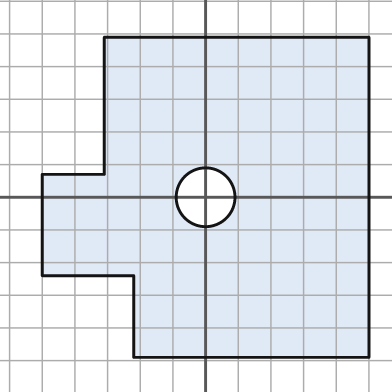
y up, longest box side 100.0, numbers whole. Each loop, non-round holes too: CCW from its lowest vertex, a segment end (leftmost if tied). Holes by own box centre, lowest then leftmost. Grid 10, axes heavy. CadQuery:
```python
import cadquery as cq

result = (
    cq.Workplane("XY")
    .moveTo(-22.0, -49.0)
    .lineTo(50.0, -49.0)
    .lineTo(50.0, 49.0)
    .lineTo(-31.0, 49.0)
    .lineTo(-31.0, 7.0)
    .lineTo(-50.0, 7.0)
    .lineTo(-50.0, -24.0)
    .lineTo(-22.0, -24.0)
    .close()
    .moveTo(0.0, 0.0)
    .circle(9.0)
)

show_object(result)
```